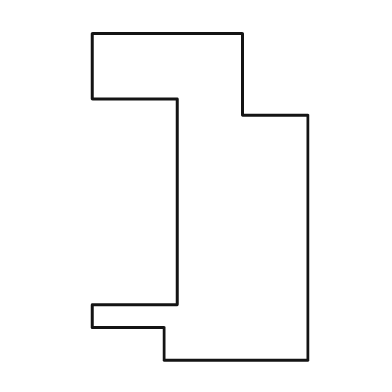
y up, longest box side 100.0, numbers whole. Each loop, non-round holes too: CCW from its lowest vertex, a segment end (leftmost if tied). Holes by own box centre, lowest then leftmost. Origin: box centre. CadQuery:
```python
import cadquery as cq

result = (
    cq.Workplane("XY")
    .moveTo(-11.0, -50.0)
    .lineTo(33.0, -50.0)
    .lineTo(33.0, 25.0)
    .lineTo(13.0, 25.0)
    .lineTo(13.0, 50.0)
    .lineTo(-33.0, 50.0)
    .lineTo(-33.0, 30.0)
    .lineTo(-7.0, 30.0)
    .lineTo(-7.0, -33.0)
    .lineTo(-33.0, -33.0)
    .lineTo(-33.0, -40.0)
    .lineTo(-11.0, -40.0)
    .close()
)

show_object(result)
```